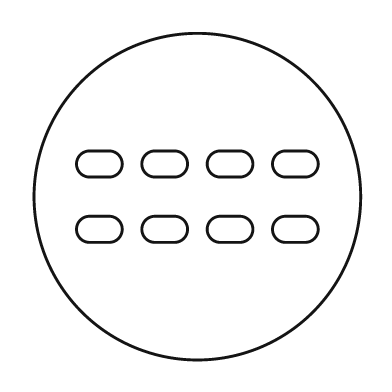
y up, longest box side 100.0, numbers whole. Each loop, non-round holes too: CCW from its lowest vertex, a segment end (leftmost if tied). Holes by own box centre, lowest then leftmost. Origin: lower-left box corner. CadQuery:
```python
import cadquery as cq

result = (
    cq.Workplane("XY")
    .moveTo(50.0, 50.0)
    .circle(50.0)
    .moveTo(17.0, 36.0)
    .lineTo(23.0, 36.0)
    .threePointArc((27.0, 40.0), (23.0, 44.0))
    .lineTo(17.0, 44.0)
    .threePointArc((13.0, 40.0), (17.0, 36.0))
    .close()
    .moveTo(37.0, 36.0)
    .lineTo(43.0, 36.0)
    .threePointArc((47.0, 40.0), (43.0, 44.0))
    .lineTo(37.0, 44.0)
    .threePointArc((33.0, 40.0), (37.0, 36.0))
    .close()
    .moveTo(57.0, 36.0)
    .lineTo(63.0, 36.0)
    .threePointArc((67.0, 40.0), (63.0, 44.0))
    .lineTo(57.0, 44.0)
    .threePointArc((53.0, 40.0), (57.0, 36.0))
    .close()
    .moveTo(77.0, 36.0)
    .lineTo(83.0, 36.0)
    .threePointArc((87.0, 40.0), (83.0, 44.0))
    .lineTo(77.0, 44.0)
    .threePointArc((73.0, 40.0), (77.0, 36.0))
    .close()
    .moveTo(17.0, 56.0)
    .lineTo(23.0, 56.0)
    .threePointArc((27.0, 60.0), (23.0, 64.0))
    .lineTo(17.0, 64.0)
    .threePointArc((13.0, 60.0), (17.0, 56.0))
    .close()
    .moveTo(37.0, 56.0)
    .lineTo(43.0, 56.0)
    .threePointArc((47.0, 60.0), (43.0, 64.0))
    .lineTo(37.0, 64.0)
    .threePointArc((33.0, 60.0), (37.0, 56.0))
    .close()
    .moveTo(57.0, 56.0)
    .lineTo(63.0, 56.0)
    .threePointArc((67.0, 60.0), (63.0, 64.0))
    .lineTo(57.0, 64.0)
    .threePointArc((53.0, 60.0), (57.0, 56.0))
    .close()
    .moveTo(77.0, 56.0)
    .lineTo(83.0, 56.0)
    .threePointArc((87.0, 60.0), (83.0, 64.0))
    .lineTo(77.0, 64.0)
    .threePointArc((73.0, 60.0), (77.0, 56.0))
    .close()
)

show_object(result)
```